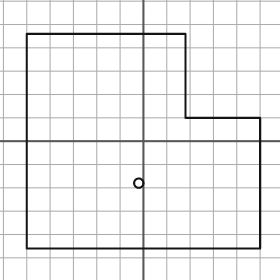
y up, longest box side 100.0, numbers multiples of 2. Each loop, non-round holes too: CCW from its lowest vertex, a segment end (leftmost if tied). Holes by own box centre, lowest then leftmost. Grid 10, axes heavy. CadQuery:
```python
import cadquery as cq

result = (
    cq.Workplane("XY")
    .moveTo(-50.0, -46.0)
    .lineTo(50.0, -46.0)
    .lineTo(50.0, 10.0)
    .lineTo(18.0, 10.0)
    .lineTo(18.0, 46.0)
    .lineTo(-50.0, 46.0)
    .close()
    .moveTo(-2.0, -18.0)
    .circle(2.0)
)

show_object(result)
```